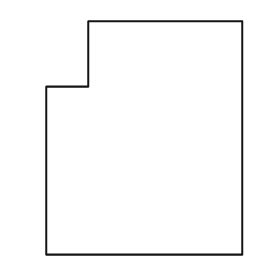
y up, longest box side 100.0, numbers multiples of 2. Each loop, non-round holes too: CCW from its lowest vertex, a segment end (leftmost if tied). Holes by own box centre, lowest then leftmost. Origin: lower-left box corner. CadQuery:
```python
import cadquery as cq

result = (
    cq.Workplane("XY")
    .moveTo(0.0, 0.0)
    .lineTo(84.0, 0.0)
    .lineTo(84.0, 100.0)
    .lineTo(18.0, 100.0)
    .lineTo(18.0, 72.0)
    .lineTo(0.0, 72.0)
    .close()
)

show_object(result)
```